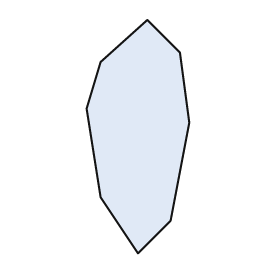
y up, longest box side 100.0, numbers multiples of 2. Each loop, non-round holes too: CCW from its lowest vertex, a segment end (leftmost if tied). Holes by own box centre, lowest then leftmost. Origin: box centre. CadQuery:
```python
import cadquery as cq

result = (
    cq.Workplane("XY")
    .moveTo(0.0, -50.0)
    .lineTo(14.0, -36.0)
    .lineTo(22.0, 6.0)
    .lineTo(18.0, 36.0)
    .lineTo(4.0, 50.0)
    .lineTo(-16.0, 32.0)
    .lineTo(-22.0, 12.0)
    .lineTo(-16.0, -26.0)
    .close()
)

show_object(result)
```